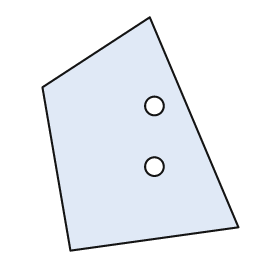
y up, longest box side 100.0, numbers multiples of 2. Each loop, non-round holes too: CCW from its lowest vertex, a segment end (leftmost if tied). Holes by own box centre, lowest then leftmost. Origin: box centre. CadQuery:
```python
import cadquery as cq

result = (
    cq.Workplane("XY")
    .moveTo(-30.0, -50.0)
    .lineTo(42.0, -40.0)
    .lineTo(4.0, 50.0)
    .lineTo(-42.0, 20.0)
    .close()
    .moveTo(6.0, -14.0)
    .circle(4.0)
    .moveTo(6.0, 12.0)
    .circle(4.0)
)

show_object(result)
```